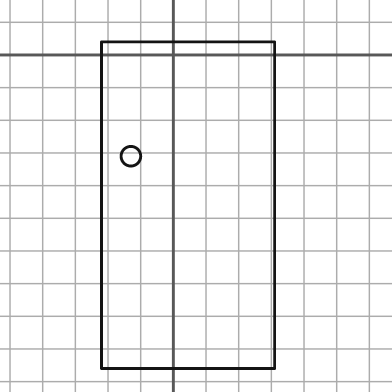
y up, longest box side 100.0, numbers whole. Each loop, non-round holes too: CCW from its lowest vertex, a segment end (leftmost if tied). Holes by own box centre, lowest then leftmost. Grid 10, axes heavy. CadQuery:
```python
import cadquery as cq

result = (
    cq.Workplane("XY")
    .moveTo(-22.0, -96.0)
    .lineTo(31.0, -96.0)
    .lineTo(31.0, 4.0)
    .lineTo(-22.0, 4.0)
    .close()
    .moveTo(-13.0, -31.0)
    .circle(3.0)
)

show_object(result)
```